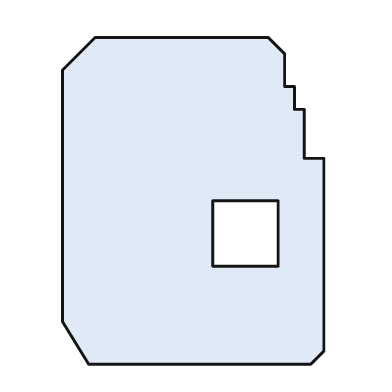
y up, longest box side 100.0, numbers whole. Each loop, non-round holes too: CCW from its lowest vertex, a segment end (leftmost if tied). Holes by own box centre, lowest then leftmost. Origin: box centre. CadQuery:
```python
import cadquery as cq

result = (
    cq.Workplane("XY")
    .moveTo(-32.0, -50.0)
    .lineTo(36.0, -50.0)
    .lineTo(40.0, -46.0)
    .lineTo(40.0, 13.0)
    .lineTo(34.0, 13.0)
    .lineTo(34.0, 28.0)
    .lineTo(31.0, 28.0)
    .lineTo(31.0, 35.0)
    .lineTo(28.0, 35.0)
    .lineTo(28.0, 45.0)
    .lineTo(23.0, 50.0)
    .lineTo(-30.0, 50.0)
    .lineTo(-40.0, 40.0)
    .lineTo(-40.0, -37.0)
    .close()
    .moveTo(6.0, -20.0)
    .lineTo(26.0, -20.0)
    .lineTo(26.0, 0.0)
    .lineTo(6.0, 0.0)
    .close()
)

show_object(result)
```